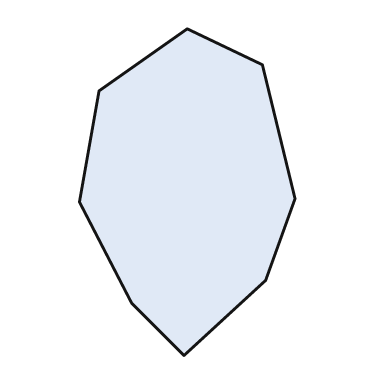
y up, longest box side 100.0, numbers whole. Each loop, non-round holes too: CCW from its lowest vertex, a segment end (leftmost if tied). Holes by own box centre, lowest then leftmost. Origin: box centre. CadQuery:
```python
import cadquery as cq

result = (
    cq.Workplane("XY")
    .moveTo(-1.0, -50.0)
    .lineTo(24.0, -27.0)
    .lineTo(33.0, -2.0)
    .lineTo(23.0, 39.0)
    .lineTo(0.0, 50.0)
    .lineTo(-27.0, 31.0)
    .lineTo(-33.0, -3.0)
    .lineTo(-17.0, -34.0)
    .close()
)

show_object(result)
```